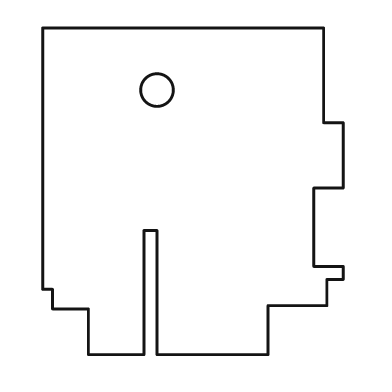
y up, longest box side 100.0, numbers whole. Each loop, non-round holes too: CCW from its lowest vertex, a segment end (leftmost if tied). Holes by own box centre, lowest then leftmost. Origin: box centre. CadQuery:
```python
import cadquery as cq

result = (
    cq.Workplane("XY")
    .moveTo(-32.0, -50.0)
    .lineTo(-15.0, -50.0)
    .lineTo(-15.0, -12.0)
    .lineTo(-11.0, -12.0)
    .lineTo(-11.0, -50.0)
    .lineTo(23.0, -50.0)
    .lineTo(23.0, -35.0)
    .lineTo(41.0, -35.0)
    .lineTo(41.0, -27.0)
    .lineTo(46.0, -27.0)
    .lineTo(46.0, -23.0)
    .lineTo(37.0, -23.0)
    .lineTo(37.0, 1.0)
    .lineTo(46.0, 1.0)
    .lineTo(46.0, 21.0)
    .lineTo(40.0, 21.0)
    .lineTo(40.0, 50.0)
    .lineTo(-46.0, 50.0)
    .lineTo(-46.0, -30.0)
    .lineTo(-43.0, -30.0)
    .lineTo(-43.0, -36.0)
    .lineTo(-32.0, -36.0)
    .close()
    .moveTo(-11.0, 31.0)
    .circle(5.0)
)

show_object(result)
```